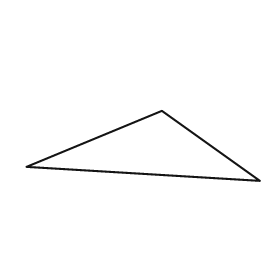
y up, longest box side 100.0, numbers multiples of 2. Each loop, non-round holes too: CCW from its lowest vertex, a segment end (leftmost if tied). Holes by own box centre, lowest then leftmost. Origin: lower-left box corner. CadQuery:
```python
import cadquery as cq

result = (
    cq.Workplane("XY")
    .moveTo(100.0, 0.0)
    .lineTo(58.0, 30.0)
    .lineTo(0.0, 6.0)
    .close()
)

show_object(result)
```